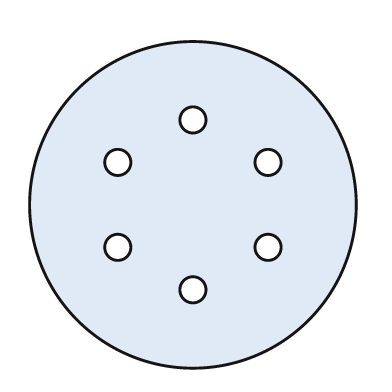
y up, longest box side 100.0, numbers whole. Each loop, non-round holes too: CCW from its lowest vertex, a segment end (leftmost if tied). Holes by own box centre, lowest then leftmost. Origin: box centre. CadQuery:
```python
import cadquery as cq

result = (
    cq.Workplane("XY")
    .moveTo(0.0, 0.0)
    .circle(50.0)
    .moveTo(0.0, -26.0)
    .circle(4.0)
    .moveTo(-23.0, -13.0)
    .circle(4.0)
    .moveTo(23.0, -13.0)
    .circle(4.0)
    .moveTo(-23.0, 13.0)
    .circle(4.0)
    .moveTo(23.0, 13.0)
    .circle(4.0)
    .moveTo(0.0, 26.0)
    .circle(4.0)
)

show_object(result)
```